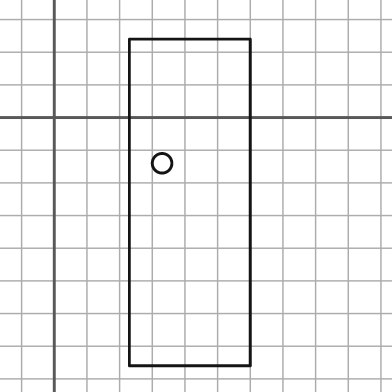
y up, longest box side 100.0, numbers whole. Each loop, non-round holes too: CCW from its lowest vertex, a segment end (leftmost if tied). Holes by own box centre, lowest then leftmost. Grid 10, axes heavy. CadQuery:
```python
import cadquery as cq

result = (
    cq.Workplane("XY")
    .moveTo(23.0, -76.0)
    .lineTo(60.0, -76.0)
    .lineTo(60.0, 24.0)
    .lineTo(23.0, 24.0)
    .close()
    .moveTo(33.0, -14.0)
    .circle(3.0)
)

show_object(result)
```